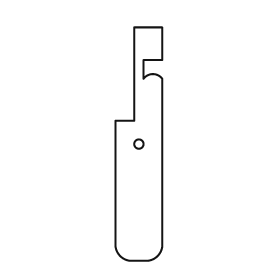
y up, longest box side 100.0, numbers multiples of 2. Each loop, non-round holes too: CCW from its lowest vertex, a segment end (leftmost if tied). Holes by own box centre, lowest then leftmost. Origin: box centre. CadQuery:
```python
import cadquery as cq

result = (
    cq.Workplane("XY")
    .moveTo(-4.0, -50.0)
    .lineTo(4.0, -50.0)
    .threePointArc((8.0, -48.0), (10.0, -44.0))
    .lineTo(10.0, 28.0)
    .threePointArc((6.0, 30.0), (2.0, 28.0))
    .lineTo(2.0, 36.0)
    .lineTo(10.0, 36.0)
    .lineTo(10.0, 50.0)
    .lineTo(-2.0, 50.0)
    .lineTo(-2.0, 10.0)
    .lineTo(-10.0, 10.0)
    .lineTo(-10.0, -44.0)
    .threePointArc((-8.0, -48.0), (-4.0, -50.0))
    .close()
    .moveTo(0.0, 0.0)
    .circle(2.0)
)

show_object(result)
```